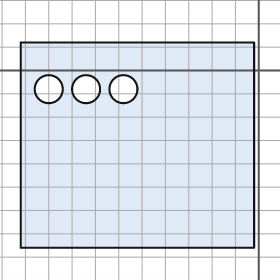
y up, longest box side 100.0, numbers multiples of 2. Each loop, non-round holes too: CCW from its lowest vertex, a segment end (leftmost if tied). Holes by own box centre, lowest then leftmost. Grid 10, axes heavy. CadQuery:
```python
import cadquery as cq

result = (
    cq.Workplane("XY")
    .moveTo(-102.0, -76.0)
    .lineTo(-2.0, -76.0)
    .lineTo(-2.0, 12.0)
    .lineTo(-102.0, 12.0)
    .close()
    .moveTo(-90.0, -8.0)
    .circle(6.0)
    .moveTo(-74.0, -8.0)
    .circle(6.0)
    .moveTo(-58.0, -8.0)
    .circle(6.0)
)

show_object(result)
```